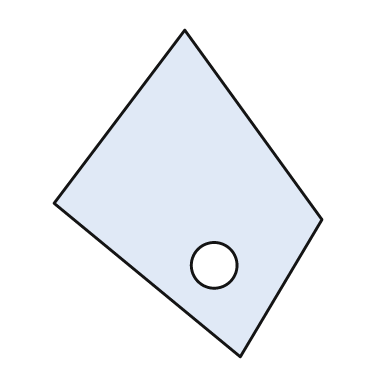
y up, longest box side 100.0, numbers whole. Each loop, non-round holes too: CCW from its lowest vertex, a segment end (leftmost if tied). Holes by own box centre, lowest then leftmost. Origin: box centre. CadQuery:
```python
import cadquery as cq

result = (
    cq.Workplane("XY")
    .moveTo(16.0, -50.0)
    .lineTo(41.0, -8.0)
    .lineTo(-1.0, 50.0)
    .lineTo(-41.0, -3.0)
    .close()
    .moveTo(8.0, -22.0)
    .circle(7.0)
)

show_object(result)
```